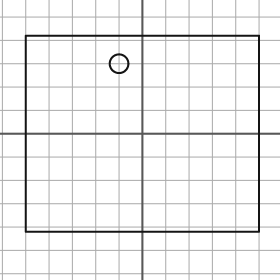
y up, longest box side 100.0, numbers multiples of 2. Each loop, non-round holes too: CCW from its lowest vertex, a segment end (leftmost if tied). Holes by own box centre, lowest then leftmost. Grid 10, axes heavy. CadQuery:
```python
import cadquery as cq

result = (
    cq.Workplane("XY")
    .moveTo(-50.0, -42.0)
    .lineTo(50.0, -42.0)
    .lineTo(50.0, 42.0)
    .lineTo(-50.0, 42.0)
    .close()
    .moveTo(-10.0, 30.0)
    .circle(4.0)
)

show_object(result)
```